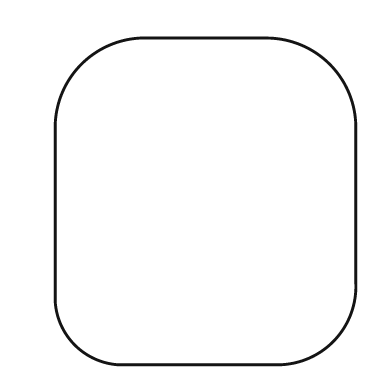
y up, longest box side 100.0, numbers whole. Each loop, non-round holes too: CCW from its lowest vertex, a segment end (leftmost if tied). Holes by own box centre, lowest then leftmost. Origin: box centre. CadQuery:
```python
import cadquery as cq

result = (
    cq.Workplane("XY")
    .moveTo(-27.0, -50.0)
    .lineTo(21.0, -50.0)
    .threePointArc((39.0, -43.0), (46.0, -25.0))
    .lineTo(46.0, 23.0)
    .threePointArc((38.0, 42.0), (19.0, 50.0))
    .lineTo(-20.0, 50.0)
    .threePointArc((-38.0, 42.0), (-46.0, 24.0))
    .lineTo(-46.0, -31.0)
    .threePointArc((-40.0, -44.0), (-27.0, -50.0))
    .close()
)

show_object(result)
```